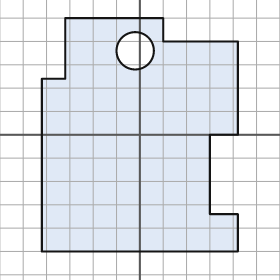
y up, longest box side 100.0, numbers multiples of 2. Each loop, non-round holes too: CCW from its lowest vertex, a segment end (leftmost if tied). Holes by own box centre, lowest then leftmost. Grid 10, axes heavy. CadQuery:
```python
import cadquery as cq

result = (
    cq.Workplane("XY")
    .moveTo(-42.0, -50.0)
    .lineTo(42.0, -50.0)
    .lineTo(42.0, -34.0)
    .lineTo(30.0, -34.0)
    .lineTo(30.0, 0.0)
    .lineTo(42.0, 0.0)
    .lineTo(42.0, 40.0)
    .lineTo(10.0, 40.0)
    .lineTo(10.0, 50.0)
    .lineTo(-32.0, 50.0)
    .lineTo(-32.0, 24.0)
    .lineTo(-42.0, 24.0)
    .close()
    .moveTo(-2.0, 36.0)
    .circle(8.0)
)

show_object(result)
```